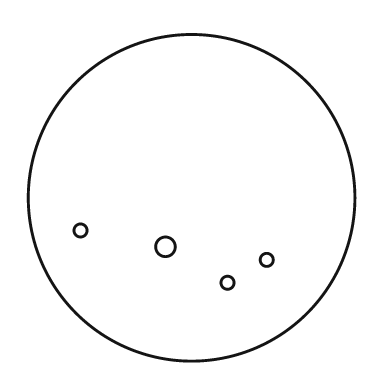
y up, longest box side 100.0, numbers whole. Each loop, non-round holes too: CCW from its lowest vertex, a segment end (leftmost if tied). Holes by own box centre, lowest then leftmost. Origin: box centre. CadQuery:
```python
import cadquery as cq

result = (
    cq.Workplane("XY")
    .moveTo(0.0, 0.0)
    .circle(50.0)
    .moveTo(11.0, -26.0)
    .circle(2.0)
    .moveTo(23.0, -19.0)
    .circle(2.0)
    .moveTo(-8.0, -15.0)
    .circle(3.0)
    .moveTo(-34.0, -10.0)
    .circle(2.0)
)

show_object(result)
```